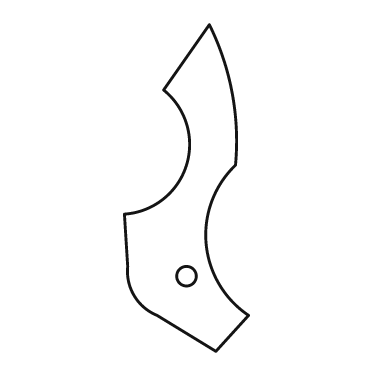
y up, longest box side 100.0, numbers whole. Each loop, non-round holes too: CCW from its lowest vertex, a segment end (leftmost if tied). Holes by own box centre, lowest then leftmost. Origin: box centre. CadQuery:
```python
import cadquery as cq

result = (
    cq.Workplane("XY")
    .moveTo(9.0, -50.0)
    .lineTo(19.0, -39.0)
    .threePointArc((6.0, -17.0), (15.0, 7.0))
    .threePointArc((14.0, 29.0), (7.0, 50.0))
    .lineTo(-7.0, 30.0)
    .threePointArc((0.0, 7.0), (-19.0, -8.0))
    .lineTo(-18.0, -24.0)
    .threePointArc((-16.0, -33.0), (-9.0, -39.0))
    .close()
    .moveTo(0.0, -27.0)
    .circle(3.0)
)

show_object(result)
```